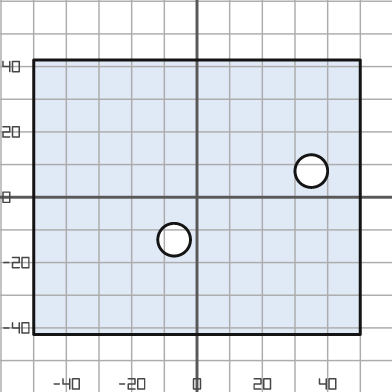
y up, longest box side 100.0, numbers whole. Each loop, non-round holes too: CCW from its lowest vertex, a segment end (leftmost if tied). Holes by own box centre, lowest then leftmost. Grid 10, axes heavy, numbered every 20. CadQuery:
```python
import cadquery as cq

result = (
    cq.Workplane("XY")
    .moveTo(-50.0, -42.0)
    .lineTo(50.0, -42.0)
    .lineTo(50.0, 42.0)
    .lineTo(-50.0, 42.0)
    .close()
    .moveTo(-7.0, -13.0)
    .circle(5.0)
    .moveTo(35.0, 8.0)
    .circle(5.0)
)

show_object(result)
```